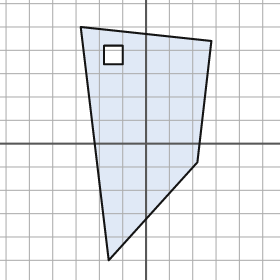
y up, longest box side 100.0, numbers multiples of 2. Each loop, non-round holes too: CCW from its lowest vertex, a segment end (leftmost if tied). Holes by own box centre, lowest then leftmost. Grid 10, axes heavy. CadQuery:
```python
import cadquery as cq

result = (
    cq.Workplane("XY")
    .moveTo(-16.0, -50.0)
    .lineTo(22.0, -8.0)
    .lineTo(28.0, 44.0)
    .lineTo(-28.0, 50.0)
    .close()
    .moveTo(-18.0, 34.0)
    .lineTo(-10.0, 34.0)
    .lineTo(-10.0, 42.0)
    .lineTo(-18.0, 42.0)
    .close()
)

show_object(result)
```